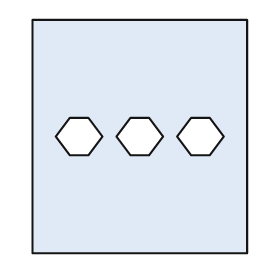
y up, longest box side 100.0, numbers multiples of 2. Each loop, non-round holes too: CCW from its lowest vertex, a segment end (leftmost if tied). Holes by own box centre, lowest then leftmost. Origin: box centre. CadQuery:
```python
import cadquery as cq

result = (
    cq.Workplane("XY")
    .moveTo(-46.0, -50.0)
    .lineTo(46.0, -50.0)
    .lineTo(46.0, 50.0)
    .lineTo(-46.0, 50.0)
    .close()
    .moveTo(-30.0, -8.0)
    .lineTo(-22.0, -8.0)
    .lineTo(-16.0, 0.0)
    .lineTo(-22.0, 8.0)
    .lineTo(-30.0, 8.0)
    .lineTo(-36.0, 0.0)
    .close()
    .moveTo(-4.0, -8.0)
    .lineTo(4.0, -8.0)
    .lineTo(10.0, 0.0)
    .lineTo(4.0, 8.0)
    .lineTo(-4.0, 8.0)
    .lineTo(-10.0, 0.0)
    .close()
    .moveTo(22.0, -8.0)
    .lineTo(30.0, -8.0)
    .lineTo(36.0, 0.0)
    .lineTo(30.0, 8.0)
    .lineTo(22.0, 8.0)
    .lineTo(16.0, 0.0)
    .close()
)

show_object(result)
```